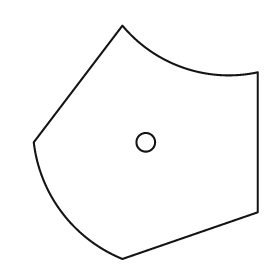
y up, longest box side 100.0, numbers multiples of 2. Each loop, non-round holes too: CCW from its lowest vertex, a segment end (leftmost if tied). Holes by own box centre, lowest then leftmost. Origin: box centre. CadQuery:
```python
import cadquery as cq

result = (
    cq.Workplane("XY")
    .moveTo(-10.0, -50.0)
    .lineTo(48.0, -30.0)
    .lineTo(48.0, 30.0)
    .threePointArc((16.0, 32.0), (-10.0, 50.0))
    .lineTo(-48.0, 0.0)
    .threePointArc((-36.0, -30.0), (-10.0, -50.0))
    .close()
    .moveTo(0.0, 0.0)
    .circle(4.0)
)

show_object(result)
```